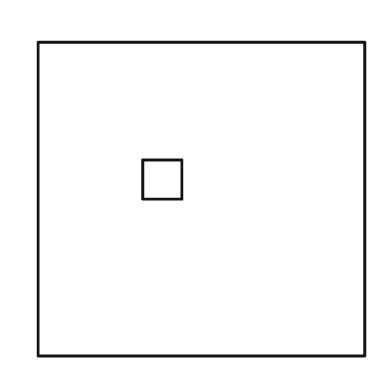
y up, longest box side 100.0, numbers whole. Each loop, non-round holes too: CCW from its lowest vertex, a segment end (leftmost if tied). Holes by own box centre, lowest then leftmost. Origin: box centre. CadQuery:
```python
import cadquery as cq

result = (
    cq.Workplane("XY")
    .moveTo(-50.0, -48.0)
    .lineTo(50.0, -48.0)
    .lineTo(50.0, 48.0)
    .lineTo(-50.0, 48.0)
    .close()
    .moveTo(-18.0, 0.0)
    .lineTo(-6.0, 0.0)
    .lineTo(-6.0, 12.0)
    .lineTo(-18.0, 12.0)
    .close()
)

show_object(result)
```